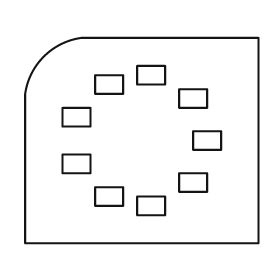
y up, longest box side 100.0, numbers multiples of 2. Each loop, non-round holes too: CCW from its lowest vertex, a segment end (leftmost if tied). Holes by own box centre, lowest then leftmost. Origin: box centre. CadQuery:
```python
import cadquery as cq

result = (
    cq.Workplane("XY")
    .moveTo(-50.0, -44.0)
    .lineTo(50.0, -44.0)
    .lineTo(50.0, 44.0)
    .lineTo(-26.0, 44.0)
    .threePointArc((-42.0, 36.0), (-50.0, 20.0))
    .close()
    .moveTo(-2.0, -32.0)
    .lineTo(10.0, -32.0)
    .lineTo(10.0, -24.0)
    .lineTo(-2.0, -24.0)
    .close()
    .moveTo(-20.0, -28.0)
    .lineTo(-8.0, -28.0)
    .lineTo(-8.0, -20.0)
    .lineTo(-20.0, -20.0)
    .close()
    .moveTo(16.0, -22.0)
    .lineTo(28.0, -22.0)
    .lineTo(28.0, -14.0)
    .lineTo(16.0, -14.0)
    .close()
    .moveTo(-34.0, -14.0)
    .lineTo(-22.0, -14.0)
    .lineTo(-22.0, -6.0)
    .lineTo(-34.0, -6.0)
    .close()
    .moveTo(22.0, -4.0)
    .lineTo(34.0, -4.0)
    .lineTo(34.0, 4.0)
    .lineTo(22.0, 4.0)
    .close()
    .moveTo(-34.0, 6.0)
    .lineTo(-22.0, 6.0)
    .lineTo(-22.0, 14.0)
    .lineTo(-34.0, 14.0)
    .close()
    .moveTo(16.0, 14.0)
    .lineTo(28.0, 14.0)
    .lineTo(28.0, 22.0)
    .lineTo(16.0, 22.0)
    .close()
    .moveTo(-20.0, 20.0)
    .lineTo(-8.0, 20.0)
    .lineTo(-8.0, 28.0)
    .lineTo(-20.0, 28.0)
    .close()
    .moveTo(-2.0, 24.0)
    .lineTo(10.0, 24.0)
    .lineTo(10.0, 32.0)
    .lineTo(-2.0, 32.0)
    .close()
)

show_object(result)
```